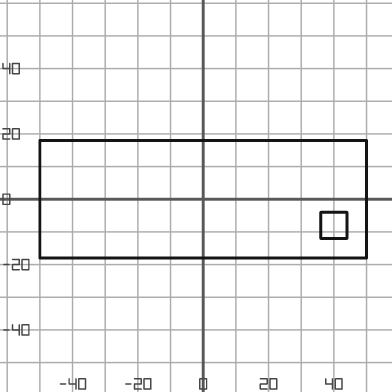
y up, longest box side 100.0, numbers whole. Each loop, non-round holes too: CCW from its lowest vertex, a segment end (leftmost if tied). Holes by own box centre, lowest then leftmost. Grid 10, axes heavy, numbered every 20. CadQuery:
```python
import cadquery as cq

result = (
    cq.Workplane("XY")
    .moveTo(-50.0, -18.0)
    .lineTo(50.0, -18.0)
    .lineTo(50.0, 18.0)
    .lineTo(-50.0, 18.0)
    .close()
    .moveTo(36.0, -12.0)
    .lineTo(44.0, -12.0)
    .lineTo(44.0, -4.0)
    .lineTo(36.0, -4.0)
    .close()
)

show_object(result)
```